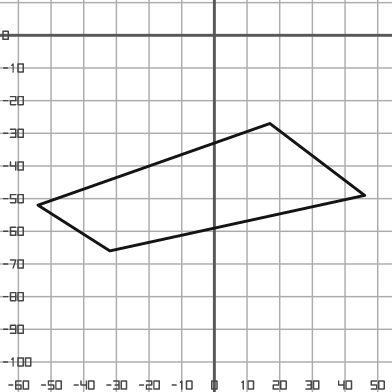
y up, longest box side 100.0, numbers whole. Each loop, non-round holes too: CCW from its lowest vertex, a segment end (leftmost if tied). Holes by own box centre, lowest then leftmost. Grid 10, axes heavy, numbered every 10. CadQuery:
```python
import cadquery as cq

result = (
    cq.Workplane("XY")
    .moveTo(-32.0, -66.0)
    .lineTo(46.0, -49.0)
    .lineTo(17.0, -27.0)
    .lineTo(-54.0, -52.0)
    .close()
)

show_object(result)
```